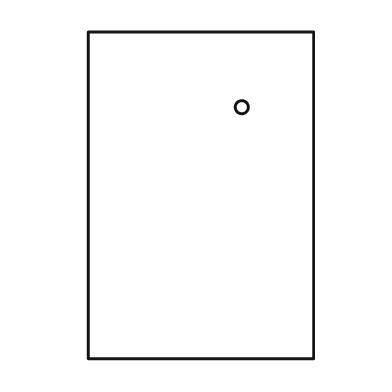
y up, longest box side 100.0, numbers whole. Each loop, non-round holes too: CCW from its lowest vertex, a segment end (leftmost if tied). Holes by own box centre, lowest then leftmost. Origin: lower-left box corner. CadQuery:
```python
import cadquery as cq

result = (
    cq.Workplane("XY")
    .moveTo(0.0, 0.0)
    .lineTo(69.0, 0.0)
    .lineTo(69.0, 100.0)
    .lineTo(0.0, 100.0)
    .close()
    .moveTo(47.0, 77.0)
    .circle(2.0)
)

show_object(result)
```